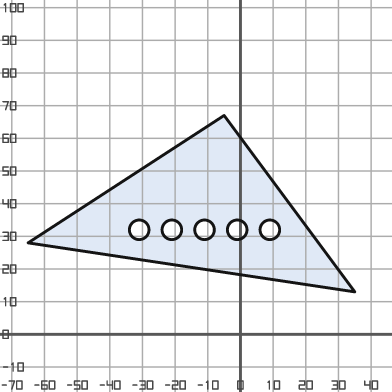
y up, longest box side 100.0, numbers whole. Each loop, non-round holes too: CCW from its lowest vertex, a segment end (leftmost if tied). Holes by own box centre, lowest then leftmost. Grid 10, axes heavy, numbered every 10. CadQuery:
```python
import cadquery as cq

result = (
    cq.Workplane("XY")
    .moveTo(35.0, 13.0)
    .lineTo(-5.0, 67.0)
    .lineTo(-65.0, 28.0)
    .close()
    .moveTo(-31.0, 32.0)
    .circle(3.0)
    .moveTo(-21.0, 32.0)
    .circle(3.0)
    .moveTo(-11.0, 32.0)
    .circle(3.0)
    .moveTo(-1.0, 32.0)
    .circle(3.0)
    .moveTo(9.0, 32.0)
    .circle(3.0)
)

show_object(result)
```